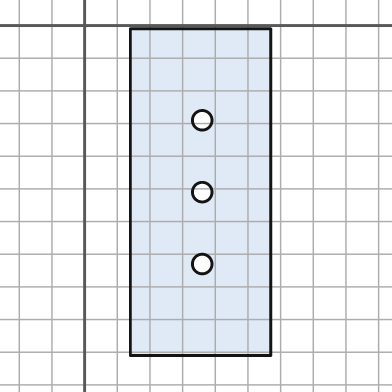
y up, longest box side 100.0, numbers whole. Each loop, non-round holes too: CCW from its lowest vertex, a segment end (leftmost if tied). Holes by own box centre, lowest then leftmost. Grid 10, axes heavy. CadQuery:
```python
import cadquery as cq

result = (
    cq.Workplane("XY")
    .moveTo(14.0, -101.0)
    .lineTo(57.0, -101.0)
    .lineTo(57.0, -1.0)
    .lineTo(14.0, -1.0)
    .close()
    .moveTo(36.0, -73.0)
    .circle(3.0)
    .moveTo(36.0, -51.0)
    .circle(3.0)
    .moveTo(36.0, -29.0)
    .circle(3.0)
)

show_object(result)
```